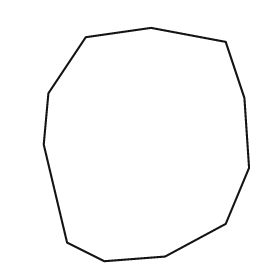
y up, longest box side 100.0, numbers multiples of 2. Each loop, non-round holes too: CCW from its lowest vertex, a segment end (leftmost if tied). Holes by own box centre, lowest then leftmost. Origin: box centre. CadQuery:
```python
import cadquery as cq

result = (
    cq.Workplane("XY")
    .moveTo(-18.0, -50.0)
    .lineTo(8.0, -48.0)
    .lineTo(34.0, -34.0)
    .lineTo(44.0, -10.0)
    .lineTo(42.0, 20.0)
    .lineTo(34.0, 44.0)
    .lineTo(2.0, 50.0)
    .lineTo(-26.0, 46.0)
    .lineTo(-42.0, 22.0)
    .lineTo(-44.0, 0.0)
    .lineTo(-34.0, -42.0)
    .close()
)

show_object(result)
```